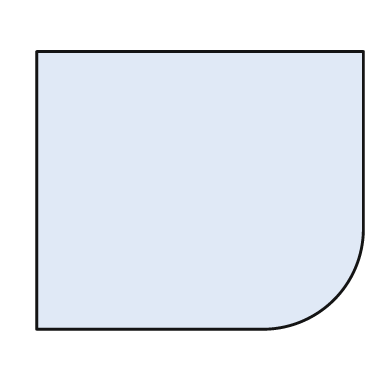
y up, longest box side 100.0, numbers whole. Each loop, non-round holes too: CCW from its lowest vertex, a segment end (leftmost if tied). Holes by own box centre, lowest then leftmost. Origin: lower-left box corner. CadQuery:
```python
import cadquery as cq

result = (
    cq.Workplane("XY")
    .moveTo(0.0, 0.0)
    .lineTo(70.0, 0.0)
    .threePointArc((91.0, 9.0), (100.0, 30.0))
    .lineTo(100.0, 85.0)
    .lineTo(0.0, 85.0)
    .close()
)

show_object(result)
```